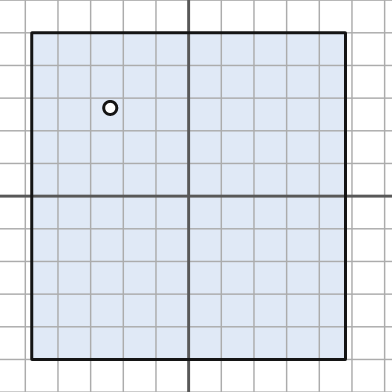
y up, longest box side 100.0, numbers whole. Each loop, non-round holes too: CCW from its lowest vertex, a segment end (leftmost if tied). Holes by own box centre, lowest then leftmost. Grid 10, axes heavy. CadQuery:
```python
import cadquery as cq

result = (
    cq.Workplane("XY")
    .moveTo(-48.0, -50.0)
    .lineTo(48.0, -50.0)
    .lineTo(48.0, 50.0)
    .lineTo(-48.0, 50.0)
    .close()
    .moveTo(-24.0, 27.0)
    .circle(2.0)
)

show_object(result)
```